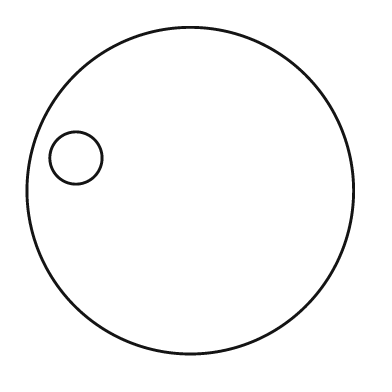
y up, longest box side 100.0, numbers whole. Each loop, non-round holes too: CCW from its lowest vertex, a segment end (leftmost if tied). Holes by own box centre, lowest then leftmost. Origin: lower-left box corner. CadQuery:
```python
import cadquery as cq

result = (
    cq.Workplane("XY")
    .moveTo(50.0, 50.0)
    .circle(50.0)
    .moveTo(15.0, 60.0)
    .circle(8.0)
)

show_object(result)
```